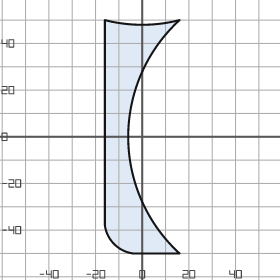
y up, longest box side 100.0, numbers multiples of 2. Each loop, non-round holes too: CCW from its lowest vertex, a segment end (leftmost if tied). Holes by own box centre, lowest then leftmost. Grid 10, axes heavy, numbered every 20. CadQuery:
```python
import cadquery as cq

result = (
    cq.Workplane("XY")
    .moveTo(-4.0, -50.0)
    .lineTo(16.0, -50.0)
    .threePointArc((-6.0, 0.0), (16.0, 50.0))
    .threePointArc((0.0, 48.0), (-16.0, 50.0))
    .lineTo(-16.0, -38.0)
    .threePointArc((-12.0, -46.0), (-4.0, -50.0))
    .close()
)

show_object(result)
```